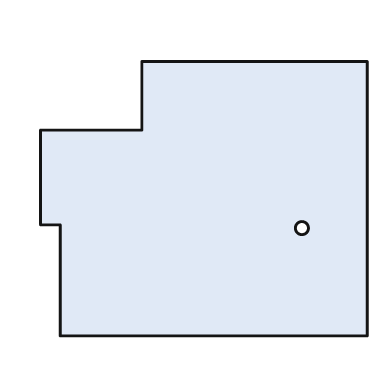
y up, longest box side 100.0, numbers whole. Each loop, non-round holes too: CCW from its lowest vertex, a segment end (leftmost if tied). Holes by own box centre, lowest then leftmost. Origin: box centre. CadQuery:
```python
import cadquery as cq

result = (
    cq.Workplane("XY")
    .moveTo(-44.0, -42.0)
    .lineTo(50.0, -42.0)
    .lineTo(50.0, 42.0)
    .lineTo(-19.0, 42.0)
    .lineTo(-19.0, 21.0)
    .lineTo(-50.0, 21.0)
    .lineTo(-50.0, -8.0)
    .lineTo(-44.0, -8.0)
    .close()
    .moveTo(30.0, -9.0)
    .circle(2.0)
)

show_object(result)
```